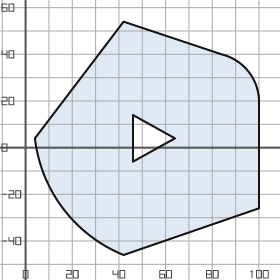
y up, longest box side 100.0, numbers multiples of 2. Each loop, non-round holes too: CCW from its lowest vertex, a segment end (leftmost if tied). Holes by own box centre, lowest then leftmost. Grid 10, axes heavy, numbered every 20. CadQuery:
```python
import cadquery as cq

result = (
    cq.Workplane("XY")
    .moveTo(42.0, -46.0)
    .lineTo(100.0, -26.0)
    .lineTo(100.0, 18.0)
    .threePointArc((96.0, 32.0), (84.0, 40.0))
    .lineTo(42.0, 54.0)
    .lineTo(4.0, 4.0)
    .threePointArc((16.0, -26.0), (42.0, -46.0))
    .close()
    .moveTo(46.0, -6.0)
    .lineTo(64.0, 4.0)
    .lineTo(46.0, 14.0)
    .close()
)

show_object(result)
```